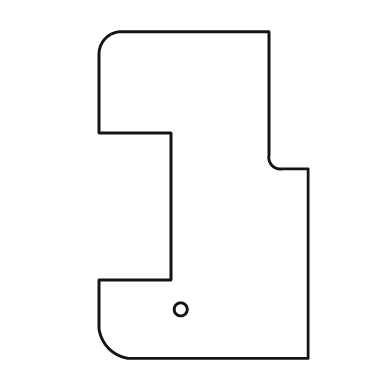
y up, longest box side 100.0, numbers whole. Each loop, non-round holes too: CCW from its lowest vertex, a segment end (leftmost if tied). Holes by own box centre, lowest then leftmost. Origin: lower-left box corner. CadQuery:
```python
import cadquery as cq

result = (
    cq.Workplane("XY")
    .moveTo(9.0, 0.0)
    .lineTo(64.0, 0.0)
    .lineTo(64.0, 58.0)
    .lineTo(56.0, 58.0)
    .threePointArc((53.0, 59.0), (52.0, 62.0))
    .lineTo(52.0, 100.0)
    .lineTo(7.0, 100.0)
    .threePointArc((2.0, 98.0), (0.0, 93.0))
    .lineTo(0.0, 69.0)
    .lineTo(22.0, 69.0)
    .lineTo(22.0, 24.0)
    .lineTo(0.0, 24.0)
    .lineTo(0.0, 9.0)
    .threePointArc((3.0, 3.0), (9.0, 0.0))
    .close()
    .moveTo(25.0, 15.0)
    .circle(2.0)
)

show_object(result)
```